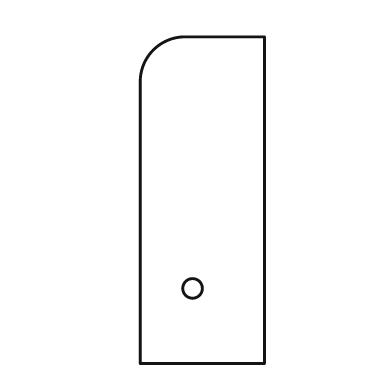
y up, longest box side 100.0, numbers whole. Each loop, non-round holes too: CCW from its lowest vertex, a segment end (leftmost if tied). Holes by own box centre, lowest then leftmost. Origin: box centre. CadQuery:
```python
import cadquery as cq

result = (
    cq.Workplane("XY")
    .moveTo(-19.0, -50.0)
    .lineTo(19.0, -50.0)
    .lineTo(19.0, 50.0)
    .lineTo(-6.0, 50.0)
    .threePointArc((-15.0, 46.0), (-19.0, 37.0))
    .close()
    .moveTo(-3.0, -27.0)
    .circle(3.0)
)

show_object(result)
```